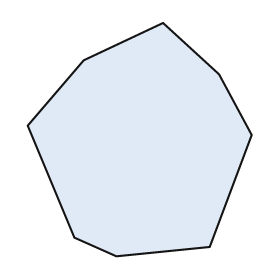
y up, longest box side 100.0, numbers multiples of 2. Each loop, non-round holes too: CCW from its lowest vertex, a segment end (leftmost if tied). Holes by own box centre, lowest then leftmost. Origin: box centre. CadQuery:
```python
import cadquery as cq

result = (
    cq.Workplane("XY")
    .moveTo(-10.0, -50.0)
    .lineTo(30.0, -46.0)
    .lineTo(48.0, 2.0)
    .lineTo(34.0, 28.0)
    .lineTo(10.0, 50.0)
    .lineTo(-24.0, 34.0)
    .lineTo(-48.0, 6.0)
    .lineTo(-28.0, -42.0)
    .close()
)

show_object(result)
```